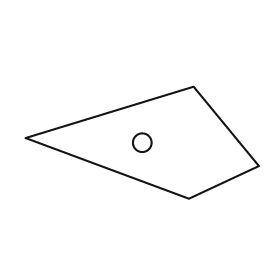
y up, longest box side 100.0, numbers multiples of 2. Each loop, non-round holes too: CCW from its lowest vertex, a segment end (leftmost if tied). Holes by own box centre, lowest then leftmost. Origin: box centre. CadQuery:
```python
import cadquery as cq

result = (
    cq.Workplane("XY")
    .moveTo(20.0, -24.0)
    .lineTo(50.0, -10.0)
    .lineTo(22.0, 24.0)
    .lineTo(-50.0, 2.0)
    .close()
    .moveTo(0.0, 0.0)
    .circle(4.0)
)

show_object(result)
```